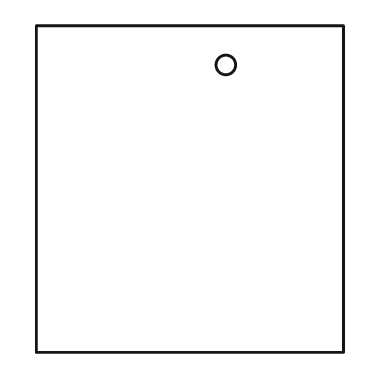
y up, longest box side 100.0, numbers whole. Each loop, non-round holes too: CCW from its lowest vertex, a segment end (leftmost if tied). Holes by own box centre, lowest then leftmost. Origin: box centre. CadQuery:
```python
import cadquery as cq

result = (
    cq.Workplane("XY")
    .moveTo(-47.0, -50.0)
    .lineTo(47.0, -50.0)
    .lineTo(47.0, 50.0)
    .lineTo(-47.0, 50.0)
    .close()
    .moveTo(11.0, 38.0)
    .circle(3.0)
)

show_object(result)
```